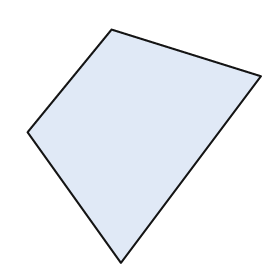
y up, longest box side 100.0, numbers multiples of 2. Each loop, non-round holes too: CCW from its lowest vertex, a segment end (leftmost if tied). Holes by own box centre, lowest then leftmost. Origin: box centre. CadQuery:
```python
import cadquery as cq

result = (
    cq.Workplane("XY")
    .moveTo(-10.0, -50.0)
    .lineTo(50.0, 30.0)
    .lineTo(-14.0, 50.0)
    .lineTo(-50.0, 6.0)
    .close()
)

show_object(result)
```